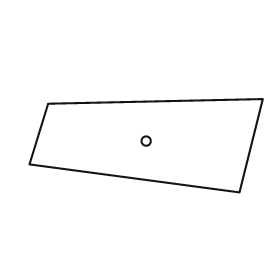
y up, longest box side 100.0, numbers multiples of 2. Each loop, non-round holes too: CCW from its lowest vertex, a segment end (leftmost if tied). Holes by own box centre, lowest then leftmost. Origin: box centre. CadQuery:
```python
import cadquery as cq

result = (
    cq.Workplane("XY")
    .moveTo(40.0, -20.0)
    .lineTo(50.0, 20.0)
    .lineTo(-42.0, 18.0)
    .lineTo(-50.0, -8.0)
    .close()
    .moveTo(0.0, 2.0)
    .circle(2.0)
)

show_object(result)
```